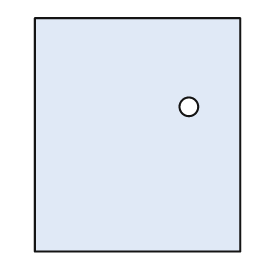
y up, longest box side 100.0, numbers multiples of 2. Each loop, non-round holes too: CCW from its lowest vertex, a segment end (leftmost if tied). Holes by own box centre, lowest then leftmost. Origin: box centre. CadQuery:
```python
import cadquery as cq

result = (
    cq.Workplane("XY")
    .moveTo(-44.0, -50.0)
    .lineTo(44.0, -50.0)
    .lineTo(44.0, 50.0)
    .lineTo(-44.0, 50.0)
    .close()
    .moveTo(22.0, 12.0)
    .circle(4.0)
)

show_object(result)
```